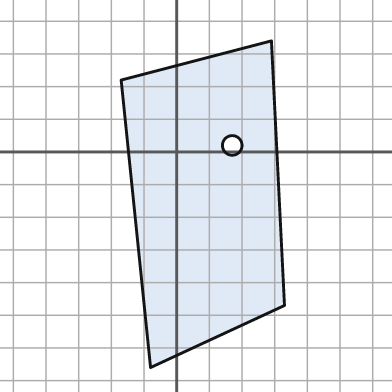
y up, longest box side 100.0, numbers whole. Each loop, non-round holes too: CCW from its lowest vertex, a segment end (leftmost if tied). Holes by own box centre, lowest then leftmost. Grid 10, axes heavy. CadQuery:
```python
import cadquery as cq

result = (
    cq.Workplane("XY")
    .moveTo(-8.0, -66.0)
    .lineTo(33.0, -47.0)
    .lineTo(29.0, 34.0)
    .lineTo(-17.0, 22.0)
    .close()
    .moveTo(17.0, 2.0)
    .circle(3.0)
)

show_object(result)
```